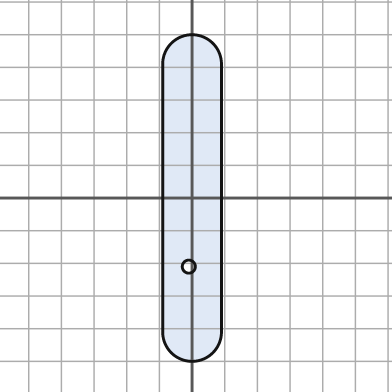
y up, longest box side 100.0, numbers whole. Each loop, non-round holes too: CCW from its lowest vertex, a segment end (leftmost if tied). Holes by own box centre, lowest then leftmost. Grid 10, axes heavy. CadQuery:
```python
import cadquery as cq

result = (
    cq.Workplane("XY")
    .moveTo(-9.0, -41.0)
    .threePointArc((0.0, -50.0), (9.0, -41.0))
    .lineTo(9.0, 41.0)
    .threePointArc((0.0, 50.0), (-9.0, 41.0))
    .close()
    .moveTo(-1.0, -21.0)
    .circle(2.0)
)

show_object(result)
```